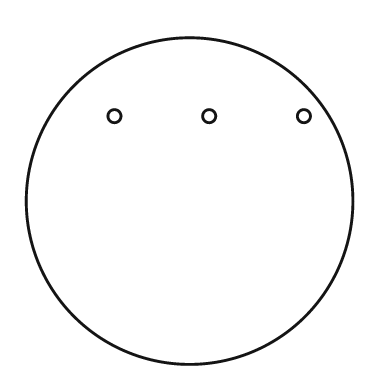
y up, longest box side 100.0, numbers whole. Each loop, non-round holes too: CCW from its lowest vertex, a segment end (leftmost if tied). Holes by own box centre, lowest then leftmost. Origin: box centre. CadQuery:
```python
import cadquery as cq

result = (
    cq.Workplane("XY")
    .moveTo(0.0, 0.0)
    .circle(50.0)
    .moveTo(-23.0, 26.0)
    .circle(2.0)
    .moveTo(6.0, 26.0)
    .circle(2.0)
    .moveTo(35.0, 26.0)
    .circle(2.0)
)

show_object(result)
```